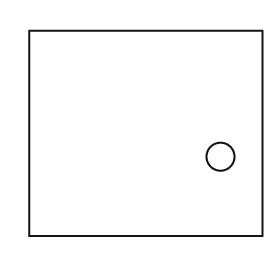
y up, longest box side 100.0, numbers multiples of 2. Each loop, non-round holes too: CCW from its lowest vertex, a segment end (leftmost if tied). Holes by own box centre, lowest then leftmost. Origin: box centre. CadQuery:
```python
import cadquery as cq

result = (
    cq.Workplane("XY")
    .moveTo(-50.0, -44.0)
    .lineTo(50.0, -44.0)
    .lineTo(50.0, 44.0)
    .lineTo(-50.0, 44.0)
    .close()
    .moveTo(32.0, -10.0)
    .circle(6.0)
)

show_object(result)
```